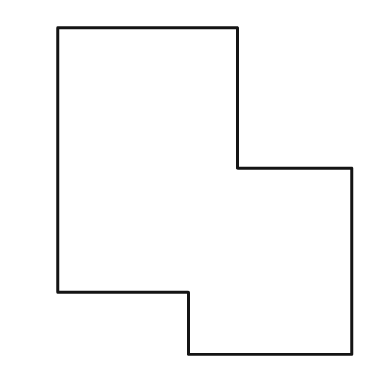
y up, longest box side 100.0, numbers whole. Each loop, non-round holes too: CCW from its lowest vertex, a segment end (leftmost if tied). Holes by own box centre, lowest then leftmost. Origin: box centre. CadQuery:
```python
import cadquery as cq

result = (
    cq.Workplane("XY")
    .moveTo(-5.0, -50.0)
    .lineTo(45.0, -50.0)
    .lineTo(45.0, 7.0)
    .lineTo(10.0, 7.0)
    .lineTo(10.0, 50.0)
    .lineTo(-45.0, 50.0)
    .lineTo(-45.0, -31.0)
    .lineTo(-5.0, -31.0)
    .close()
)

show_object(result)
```